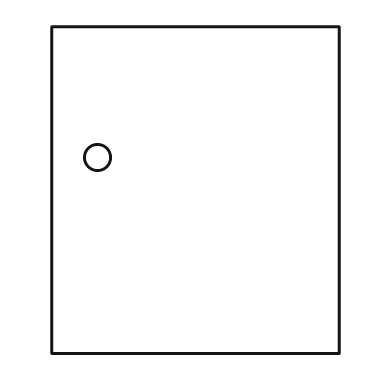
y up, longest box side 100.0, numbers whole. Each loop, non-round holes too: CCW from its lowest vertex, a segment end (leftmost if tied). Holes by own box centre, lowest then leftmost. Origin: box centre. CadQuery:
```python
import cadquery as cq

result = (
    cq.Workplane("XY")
    .moveTo(-44.0, -50.0)
    .lineTo(44.0, -50.0)
    .lineTo(44.0, 50.0)
    .lineTo(-44.0, 50.0)
    .close()
    .moveTo(-30.0, 10.0)
    .circle(4.0)
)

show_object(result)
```